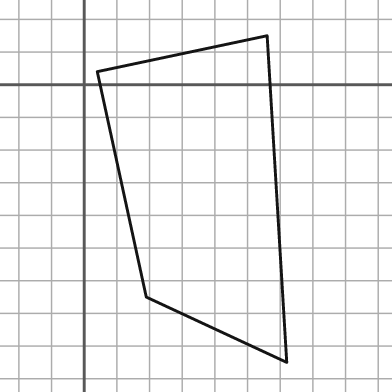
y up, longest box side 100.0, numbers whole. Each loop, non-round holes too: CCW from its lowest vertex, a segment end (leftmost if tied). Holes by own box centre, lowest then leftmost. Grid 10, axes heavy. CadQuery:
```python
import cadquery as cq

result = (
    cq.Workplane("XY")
    .moveTo(62.0, -85.0)
    .lineTo(56.0, 15.0)
    .lineTo(4.0, 4.0)
    .lineTo(19.0, -65.0)
    .close()
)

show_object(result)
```